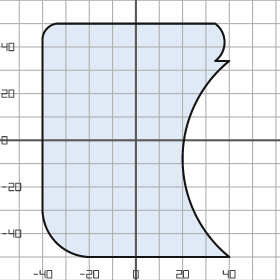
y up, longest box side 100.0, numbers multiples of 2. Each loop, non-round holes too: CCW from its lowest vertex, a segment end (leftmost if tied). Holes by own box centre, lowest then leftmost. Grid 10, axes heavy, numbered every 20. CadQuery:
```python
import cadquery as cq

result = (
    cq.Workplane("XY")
    .moveTo(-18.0, -50.0)
    .lineTo(40.0, -50.0)
    .threePointArc((20.0, -8.0), (40.0, 34.0))
    .lineTo(34.0, 34.0)
    .threePointArc((38.0, 42.0), (34.0, 50.0))
    .lineTo(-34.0, 50.0)
    .threePointArc((-38.0, 48.0), (-40.0, 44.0))
    .lineTo(-40.0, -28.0)
    .threePointArc((-34.0, -44.0), (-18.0, -50.0))
    .close()
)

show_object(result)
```